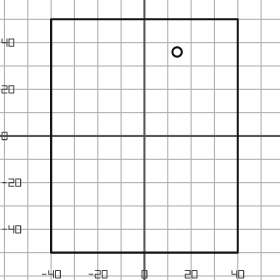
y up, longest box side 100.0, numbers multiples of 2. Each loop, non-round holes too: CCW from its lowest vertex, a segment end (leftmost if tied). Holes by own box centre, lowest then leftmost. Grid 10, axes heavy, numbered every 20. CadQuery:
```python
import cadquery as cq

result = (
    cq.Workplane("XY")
    .moveTo(-40.0, -50.0)
    .lineTo(40.0, -50.0)
    .lineTo(40.0, 50.0)
    .lineTo(-40.0, 50.0)
    .close()
    .moveTo(14.0, 36.0)
    .circle(2.0)
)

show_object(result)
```